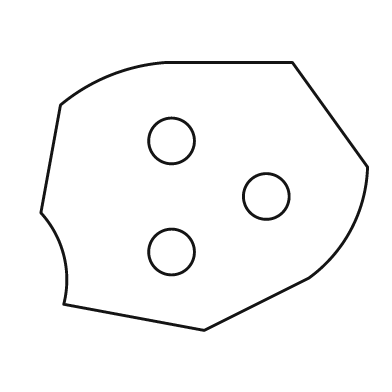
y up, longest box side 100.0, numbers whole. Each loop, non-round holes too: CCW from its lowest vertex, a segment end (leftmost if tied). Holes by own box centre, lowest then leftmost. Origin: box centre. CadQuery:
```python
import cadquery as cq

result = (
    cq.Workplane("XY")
    .moveTo(0.0, -41.0)
    .lineTo(32.0, -25.0)
    .threePointArc((45.0, -10.0), (50.0, 9.0))
    .lineTo(27.0, 41.0)
    .lineTo(-12.0, 41.0)
    .threePointArc((-29.0, 37.0), (-44.0, 28.0))
    .lineTo(-50.0, -5.0)
    .threePointArc((-43.0, -18.0), (-43.0, -33.0))
    .close()
    .moveTo(-10.0, -17.0)
    .circle(7.0)
    .moveTo(19.0, 0.0)
    .circle(7.0)
    .moveTo(-10.0, 17.0)
    .circle(7.0)
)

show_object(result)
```